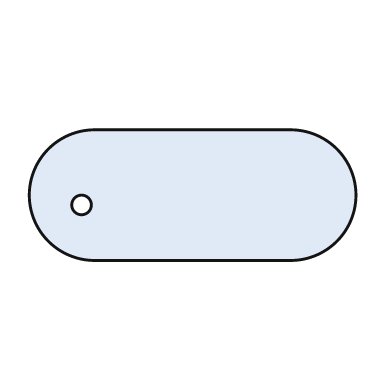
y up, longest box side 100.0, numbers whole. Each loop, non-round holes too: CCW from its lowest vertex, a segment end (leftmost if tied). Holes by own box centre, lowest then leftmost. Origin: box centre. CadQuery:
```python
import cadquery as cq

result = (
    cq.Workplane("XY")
    .moveTo(-30.0, -20.0)
    .lineTo(30.0, -20.0)
    .threePointArc((50.0, 0.0), (30.0, 20.0))
    .lineTo(-30.0, 20.0)
    .threePointArc((-50.0, 0.0), (-30.0, -20.0))
    .close()
    .moveTo(-34.0, -3.0)
    .circle(3.0)
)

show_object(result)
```